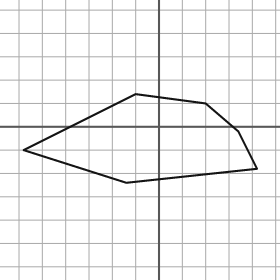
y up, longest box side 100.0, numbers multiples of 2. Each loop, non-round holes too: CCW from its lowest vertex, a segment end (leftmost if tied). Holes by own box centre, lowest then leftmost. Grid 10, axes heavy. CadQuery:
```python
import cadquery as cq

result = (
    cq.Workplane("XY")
    .moveTo(-14.0, -24.0)
    .lineTo(42.0, -18.0)
    .lineTo(34.0, -2.0)
    .lineTo(20.0, 10.0)
    .lineTo(-10.0, 14.0)
    .lineTo(-58.0, -10.0)
    .close()
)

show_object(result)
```